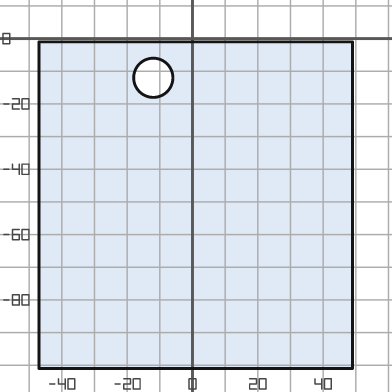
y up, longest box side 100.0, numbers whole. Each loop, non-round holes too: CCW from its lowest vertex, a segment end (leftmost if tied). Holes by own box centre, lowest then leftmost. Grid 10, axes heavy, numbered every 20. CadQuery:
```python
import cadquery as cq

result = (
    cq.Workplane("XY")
    .moveTo(-47.0, -101.0)
    .lineTo(49.0, -101.0)
    .lineTo(49.0, -1.0)
    .lineTo(-47.0, -1.0)
    .close()
    .moveTo(-12.0, -12.0)
    .circle(6.0)
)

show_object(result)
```